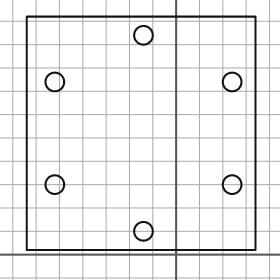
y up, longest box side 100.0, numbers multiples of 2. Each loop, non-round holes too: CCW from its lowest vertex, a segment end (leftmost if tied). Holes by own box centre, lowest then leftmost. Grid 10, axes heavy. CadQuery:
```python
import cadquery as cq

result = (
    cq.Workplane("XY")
    .moveTo(-64.0, 2.0)
    .lineTo(34.0, 2.0)
    .lineTo(34.0, 102.0)
    .lineTo(-64.0, 102.0)
    .close()
    .moveTo(-14.0, 10.0)
    .circle(4.0)
    .moveTo(-52.0, 30.0)
    .circle(4.0)
    .moveTo(24.0, 30.0)
    .circle(4.0)
    .moveTo(-52.0, 74.0)
    .circle(4.0)
    .moveTo(24.0, 74.0)
    .circle(4.0)
    .moveTo(-14.0, 94.0)
    .circle(4.0)
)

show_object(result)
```